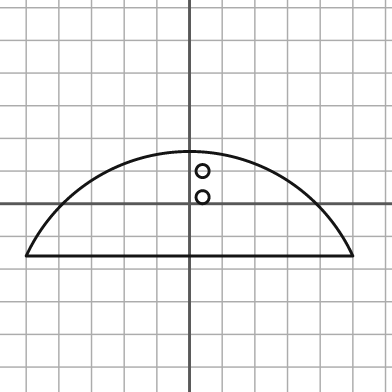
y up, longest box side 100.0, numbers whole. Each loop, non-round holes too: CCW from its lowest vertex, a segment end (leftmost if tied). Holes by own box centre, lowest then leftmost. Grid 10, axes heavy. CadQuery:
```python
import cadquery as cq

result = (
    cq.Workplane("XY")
    .moveTo(-50.0, -16.0)
    .lineTo(50.0, -16.0)
    .threePointArc((0.0, 16.0), (-50.0, -16.0))
    .close()
    .moveTo(4.0, 2.0)
    .circle(2.0)
    .moveTo(4.0, 10.0)
    .circle(2.0)
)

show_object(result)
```